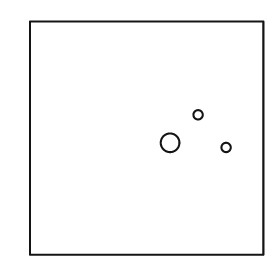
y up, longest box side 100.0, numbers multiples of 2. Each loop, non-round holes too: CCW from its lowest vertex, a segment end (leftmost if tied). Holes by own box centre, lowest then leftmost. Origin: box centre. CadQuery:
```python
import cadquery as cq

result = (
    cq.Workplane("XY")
    .moveTo(-50.0, -50.0)
    .lineTo(50.0, -50.0)
    .lineTo(50.0, 50.0)
    .lineTo(-50.0, 50.0)
    .close()
    .moveTo(34.0, -4.0)
    .circle(2.0)
    .moveTo(10.0, -2.0)
    .circle(4.0)
    .moveTo(22.0, 10.0)
    .circle(2.0)
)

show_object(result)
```